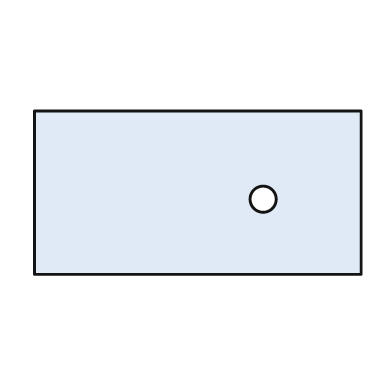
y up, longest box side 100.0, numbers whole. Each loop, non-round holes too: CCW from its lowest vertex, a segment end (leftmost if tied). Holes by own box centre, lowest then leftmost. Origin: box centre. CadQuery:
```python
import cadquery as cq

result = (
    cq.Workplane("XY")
    .moveTo(-50.0, -25.0)
    .lineTo(50.0, -25.0)
    .lineTo(50.0, 25.0)
    .lineTo(-50.0, 25.0)
    .close()
    .moveTo(20.0, -2.0)
    .circle(4.0)
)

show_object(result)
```